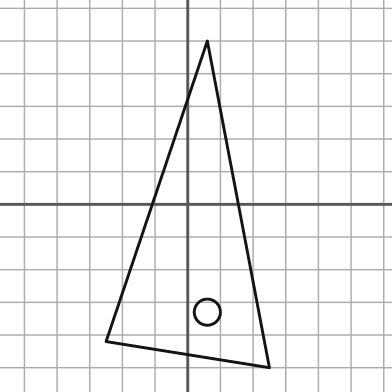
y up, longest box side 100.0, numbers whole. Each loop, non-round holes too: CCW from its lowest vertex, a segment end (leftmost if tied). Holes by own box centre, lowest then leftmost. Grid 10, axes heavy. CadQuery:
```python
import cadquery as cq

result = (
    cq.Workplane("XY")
    .moveTo(25.0, -50.0)
    .lineTo(6.0, 50.0)
    .lineTo(-25.0, -42.0)
    .close()
    .moveTo(6.0, -33.0)
    .circle(4.0)
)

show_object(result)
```